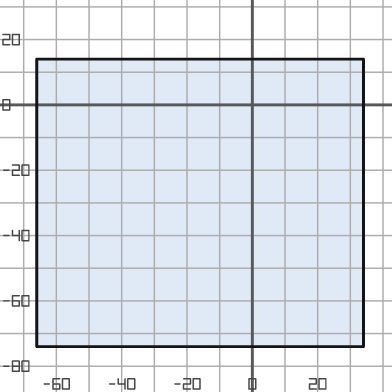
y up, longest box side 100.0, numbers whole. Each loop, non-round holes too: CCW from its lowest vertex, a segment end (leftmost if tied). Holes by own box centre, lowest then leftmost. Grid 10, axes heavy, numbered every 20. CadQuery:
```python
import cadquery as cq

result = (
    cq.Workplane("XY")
    .moveTo(-66.0, -74.0)
    .lineTo(34.0, -74.0)
    .lineTo(34.0, 14.0)
    .lineTo(-66.0, 14.0)
    .close()
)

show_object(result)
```